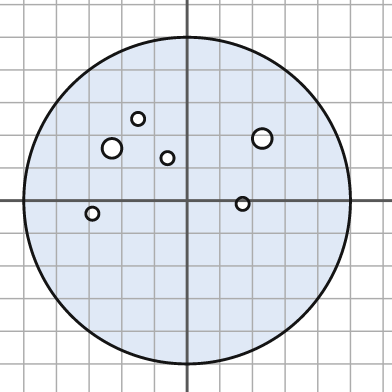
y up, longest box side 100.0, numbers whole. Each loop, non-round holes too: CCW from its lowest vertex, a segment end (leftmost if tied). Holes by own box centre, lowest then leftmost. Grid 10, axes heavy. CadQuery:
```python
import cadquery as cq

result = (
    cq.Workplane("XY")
    .moveTo(0.0, 0.0)
    .circle(50.0)
    .moveTo(-29.0, -4.0)
    .circle(2.0)
    .moveTo(17.0, -1.0)
    .circle(2.0)
    .moveTo(-6.0, 13.0)
    .circle(2.0)
    .moveTo(-23.0, 16.0)
    .circle(3.0)
    .moveTo(23.0, 19.0)
    .circle(3.0)
    .moveTo(-15.0, 25.0)
    .circle(2.0)
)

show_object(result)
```